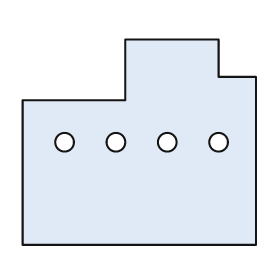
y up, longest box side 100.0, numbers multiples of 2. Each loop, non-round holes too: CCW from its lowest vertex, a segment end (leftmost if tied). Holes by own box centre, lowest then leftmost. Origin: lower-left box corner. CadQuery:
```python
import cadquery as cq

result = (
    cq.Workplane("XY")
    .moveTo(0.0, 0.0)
    .lineTo(100.0, 0.0)
    .lineTo(100.0, 72.0)
    .lineTo(84.0, 72.0)
    .lineTo(84.0, 88.0)
    .lineTo(44.0, 88.0)
    .lineTo(44.0, 62.0)
    .lineTo(0.0, 62.0)
    .close()
    .moveTo(18.0, 44.0)
    .circle(4.0)
    .moveTo(40.0, 44.0)
    .circle(4.0)
    .moveTo(62.0, 44.0)
    .circle(4.0)
    .moveTo(84.0, 44.0)
    .circle(4.0)
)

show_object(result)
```